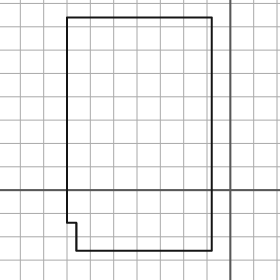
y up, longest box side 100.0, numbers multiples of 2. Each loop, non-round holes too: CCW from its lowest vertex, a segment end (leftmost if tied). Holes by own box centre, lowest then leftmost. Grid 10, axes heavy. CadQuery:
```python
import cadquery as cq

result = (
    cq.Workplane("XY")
    .moveTo(-66.0, -26.0)
    .lineTo(-8.0, -26.0)
    .lineTo(-8.0, 74.0)
    .lineTo(-70.0, 74.0)
    .lineTo(-70.0, -14.0)
    .lineTo(-66.0, -14.0)
    .close()
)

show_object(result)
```